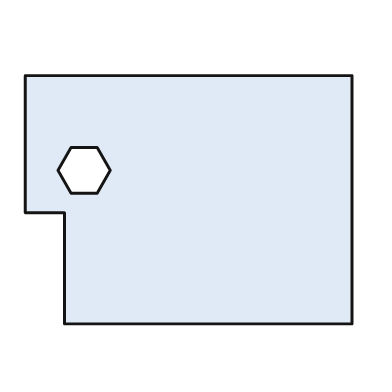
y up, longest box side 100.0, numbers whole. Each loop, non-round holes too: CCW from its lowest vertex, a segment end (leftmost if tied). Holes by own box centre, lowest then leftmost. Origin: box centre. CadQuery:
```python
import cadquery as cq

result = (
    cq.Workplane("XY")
    .moveTo(-38.0, -38.0)
    .lineTo(50.0, -38.0)
    .lineTo(50.0, 38.0)
    .lineTo(-50.0, 38.0)
    .lineTo(-50.0, -4.0)
    .lineTo(-38.0, -4.0)
    .close()
    .moveTo(-36.0, 2.0)
    .lineTo(-28.0, 2.0)
    .lineTo(-24.0, 9.0)
    .lineTo(-28.0, 16.0)
    .lineTo(-36.0, 16.0)
    .lineTo(-40.0, 9.0)
    .close()
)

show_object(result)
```